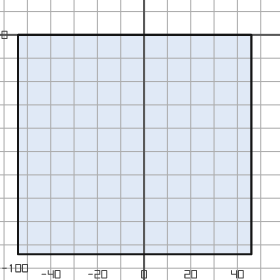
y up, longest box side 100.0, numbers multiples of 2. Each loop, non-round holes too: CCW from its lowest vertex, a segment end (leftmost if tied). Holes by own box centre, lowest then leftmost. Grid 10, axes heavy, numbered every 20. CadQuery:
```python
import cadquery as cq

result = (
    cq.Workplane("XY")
    .moveTo(-54.0, -94.0)
    .lineTo(46.0, -94.0)
    .lineTo(46.0, 0.0)
    .lineTo(-54.0, 0.0)
    .close()
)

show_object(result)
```